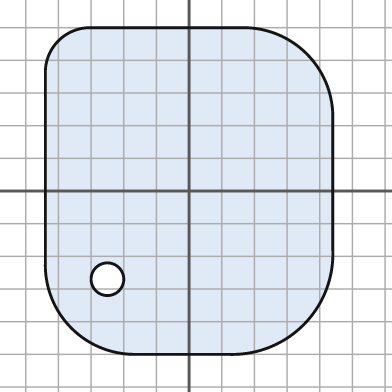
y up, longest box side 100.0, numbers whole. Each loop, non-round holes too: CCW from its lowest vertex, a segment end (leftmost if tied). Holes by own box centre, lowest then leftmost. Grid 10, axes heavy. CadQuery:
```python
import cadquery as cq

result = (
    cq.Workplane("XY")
    .moveTo(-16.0, -50.0)
    .lineTo(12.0, -50.0)
    .threePointArc((35.0, -41.0), (44.0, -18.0))
    .lineTo(44.0, 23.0)
    .threePointArc((36.0, 42.0), (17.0, 50.0))
    .lineTo(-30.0, 50.0)
    .threePointArc((-40.0, 46.0), (-44.0, 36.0))
    .lineTo(-44.0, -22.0)
    .threePointArc((-36.0, -42.0), (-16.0, -50.0))
    .close()
    .moveTo(-25.0, -27.0)
    .circle(5.0)
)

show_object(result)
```